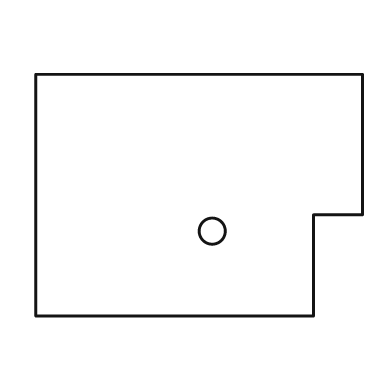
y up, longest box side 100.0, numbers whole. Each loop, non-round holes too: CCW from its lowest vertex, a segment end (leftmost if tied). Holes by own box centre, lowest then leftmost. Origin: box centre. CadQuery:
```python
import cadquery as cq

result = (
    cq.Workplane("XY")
    .moveTo(-50.0, -37.0)
    .lineTo(35.0, -37.0)
    .lineTo(35.0, -6.0)
    .lineTo(50.0, -6.0)
    .lineTo(50.0, 37.0)
    .lineTo(-50.0, 37.0)
    .close()
    .moveTo(4.0, -11.0)
    .circle(4.0)
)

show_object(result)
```